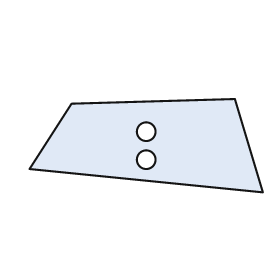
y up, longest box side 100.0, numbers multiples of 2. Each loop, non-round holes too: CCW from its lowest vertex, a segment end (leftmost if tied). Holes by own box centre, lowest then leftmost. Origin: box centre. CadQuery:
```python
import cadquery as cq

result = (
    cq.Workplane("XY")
    .moveTo(50.0, -20.0)
    .lineTo(38.0, 20.0)
    .lineTo(-32.0, 18.0)
    .lineTo(-50.0, -10.0)
    .close()
    .moveTo(0.0, -6.0)
    .circle(4.0)
    .moveTo(0.0, 6.0)
    .circle(4.0)
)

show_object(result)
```